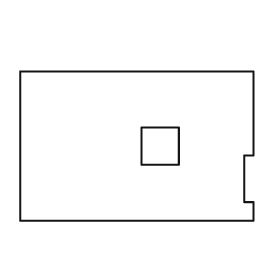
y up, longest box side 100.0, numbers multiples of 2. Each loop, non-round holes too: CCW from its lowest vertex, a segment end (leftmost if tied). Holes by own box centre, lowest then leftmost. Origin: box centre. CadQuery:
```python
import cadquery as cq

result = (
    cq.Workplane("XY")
    .moveTo(-50.0, -32.0)
    .lineTo(50.0, -32.0)
    .lineTo(50.0, -24.0)
    .lineTo(46.0, -24.0)
    .lineTo(46.0, -4.0)
    .lineTo(50.0, -4.0)
    .lineTo(50.0, 32.0)
    .lineTo(-50.0, 32.0)
    .close()
    .moveTo(2.0, -8.0)
    .lineTo(18.0, -8.0)
    .lineTo(18.0, 8.0)
    .lineTo(2.0, 8.0)
    .close()
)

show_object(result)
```